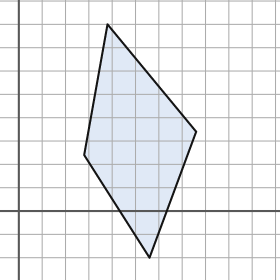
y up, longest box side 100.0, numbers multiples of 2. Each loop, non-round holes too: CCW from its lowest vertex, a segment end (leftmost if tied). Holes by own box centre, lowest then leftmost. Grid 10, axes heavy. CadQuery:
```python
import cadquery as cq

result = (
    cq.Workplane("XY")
    .moveTo(56.0, -20.0)
    .lineTo(76.0, 34.0)
    .lineTo(38.0, 80.0)
    .lineTo(28.0, 24.0)
    .close()
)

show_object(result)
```